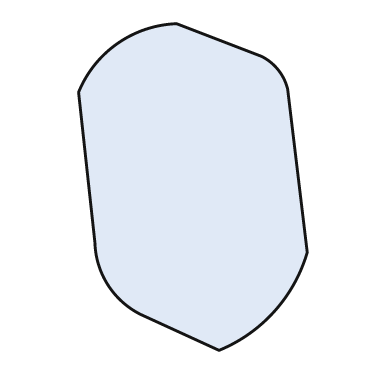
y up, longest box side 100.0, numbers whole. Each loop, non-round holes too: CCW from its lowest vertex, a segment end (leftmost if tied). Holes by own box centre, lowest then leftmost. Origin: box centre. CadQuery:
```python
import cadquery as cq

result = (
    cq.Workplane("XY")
    .moveTo(8.0, -50.0)
    .threePointArc((25.0, -38.0), (35.0, -20.0))
    .lineTo(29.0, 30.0)
    .threePointArc((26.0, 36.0), (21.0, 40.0))
    .lineTo(-5.0, 50.0)
    .threePointArc((-23.0, 44.0), (-35.0, 29.0))
    .lineTo(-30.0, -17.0)
    .threePointArc((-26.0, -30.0), (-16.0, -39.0))
    .close()
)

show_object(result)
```